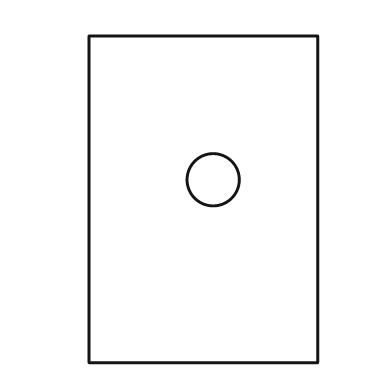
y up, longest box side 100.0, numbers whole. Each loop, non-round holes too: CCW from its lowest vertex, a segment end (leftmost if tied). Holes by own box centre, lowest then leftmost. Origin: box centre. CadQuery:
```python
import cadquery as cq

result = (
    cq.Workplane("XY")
    .moveTo(-35.0, -50.0)
    .lineTo(35.0, -50.0)
    .lineTo(35.0, 50.0)
    .lineTo(-35.0, 50.0)
    .close()
    .moveTo(3.0, 6.0)
    .circle(8.0)
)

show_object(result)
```